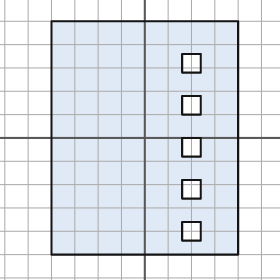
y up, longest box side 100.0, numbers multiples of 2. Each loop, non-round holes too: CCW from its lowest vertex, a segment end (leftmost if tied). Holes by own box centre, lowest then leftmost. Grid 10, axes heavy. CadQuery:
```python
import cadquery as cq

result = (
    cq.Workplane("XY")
    .moveTo(-40.0, -50.0)
    .lineTo(40.0, -50.0)
    .lineTo(40.0, 50.0)
    .lineTo(-40.0, 50.0)
    .close()
    .moveTo(16.0, -44.0)
    .lineTo(24.0, -44.0)
    .lineTo(24.0, -36.0)
    .lineTo(16.0, -36.0)
    .close()
    .moveTo(16.0, -26.0)
    .lineTo(24.0, -26.0)
    .lineTo(24.0, -18.0)
    .lineTo(16.0, -18.0)
    .close()
    .moveTo(16.0, -8.0)
    .lineTo(24.0, -8.0)
    .lineTo(24.0, 0.0)
    .lineTo(16.0, 0.0)
    .close()
    .moveTo(16.0, 10.0)
    .lineTo(24.0, 10.0)
    .lineTo(24.0, 18.0)
    .lineTo(16.0, 18.0)
    .close()
    .moveTo(16.0, 28.0)
    .lineTo(24.0, 28.0)
    .lineTo(24.0, 36.0)
    .lineTo(16.0, 36.0)
    .close()
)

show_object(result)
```